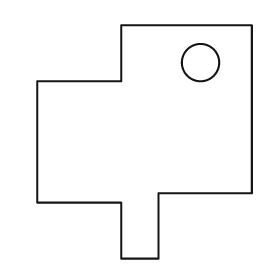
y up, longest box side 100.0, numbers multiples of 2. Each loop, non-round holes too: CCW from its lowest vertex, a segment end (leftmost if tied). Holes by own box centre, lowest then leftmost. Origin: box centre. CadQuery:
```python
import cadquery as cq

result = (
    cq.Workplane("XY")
    .moveTo(-10.0, -50.0)
    .lineTo(6.0, -50.0)
    .lineTo(6.0, -22.0)
    .lineTo(46.0, -22.0)
    .lineTo(46.0, 50.0)
    .lineTo(-10.0, 50.0)
    .lineTo(-10.0, 26.0)
    .lineTo(-46.0, 26.0)
    .lineTo(-46.0, -26.0)
    .lineTo(-10.0, -26.0)
    .close()
    .moveTo(24.0, 34.0)
    .circle(8.0)
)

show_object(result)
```